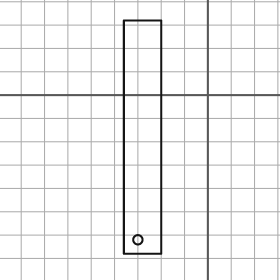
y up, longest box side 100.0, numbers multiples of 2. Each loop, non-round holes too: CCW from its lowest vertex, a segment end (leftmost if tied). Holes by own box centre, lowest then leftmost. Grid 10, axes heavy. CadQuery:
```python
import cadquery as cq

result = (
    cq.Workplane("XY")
    .moveTo(-36.0, -68.0)
    .lineTo(-20.0, -68.0)
    .lineTo(-20.0, 32.0)
    .lineTo(-36.0, 32.0)
    .close()
    .moveTo(-30.0, -62.0)
    .circle(2.0)
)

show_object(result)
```